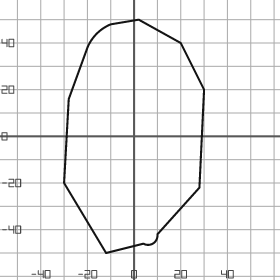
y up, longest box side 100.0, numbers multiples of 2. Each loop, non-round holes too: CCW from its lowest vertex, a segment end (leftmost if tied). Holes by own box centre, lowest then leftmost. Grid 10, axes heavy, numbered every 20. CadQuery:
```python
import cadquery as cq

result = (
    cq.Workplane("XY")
    .moveTo(-12.0, -50.0)
    .lineTo(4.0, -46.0)
    .threePointArc((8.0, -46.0), (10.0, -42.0))
    .lineTo(28.0, -22.0)
    .lineTo(30.0, 20.0)
    .lineTo(20.0, 40.0)
    .lineTo(2.0, 50.0)
    .lineTo(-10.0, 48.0)
    .threePointArc((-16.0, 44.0), (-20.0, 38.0))
    .lineTo(-28.0, 16.0)
    .lineTo(-30.0, -20.0)
    .close()
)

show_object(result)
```